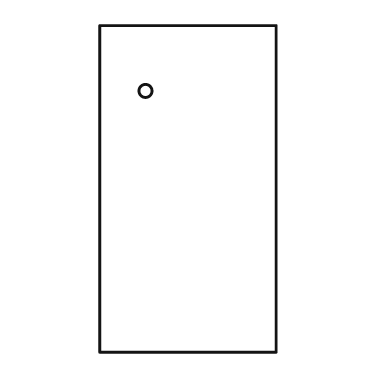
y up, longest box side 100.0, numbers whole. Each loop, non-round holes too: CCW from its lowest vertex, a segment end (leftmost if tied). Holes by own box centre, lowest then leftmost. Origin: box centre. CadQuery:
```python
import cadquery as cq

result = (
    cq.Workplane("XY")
    .moveTo(-27.0, -50.0)
    .lineTo(27.0, -50.0)
    .lineTo(27.0, 50.0)
    .lineTo(-27.0, 50.0)
    .close()
    .moveTo(-13.0, 30.0)
    .circle(2.0)
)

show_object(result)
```